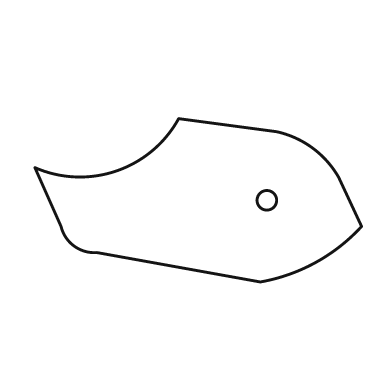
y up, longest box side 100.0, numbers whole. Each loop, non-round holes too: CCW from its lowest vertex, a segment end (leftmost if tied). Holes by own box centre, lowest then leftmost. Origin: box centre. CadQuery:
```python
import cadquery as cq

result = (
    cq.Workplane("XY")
    .moveTo(19.0, -25.0)
    .threePointArc((36.0, -19.0), (50.0, -8.0))
    .lineTo(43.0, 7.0)
    .threePointArc((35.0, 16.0), (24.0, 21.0))
    .lineTo(-6.0, 25.0)
    .threePointArc((-25.0, 9.0), (-50.0, 10.0))
    .lineTo(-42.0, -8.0)
    .threePointArc((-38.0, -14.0), (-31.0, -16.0))
    .close()
    .moveTo(21.0, 0.0)
    .circle(3.0)
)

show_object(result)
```